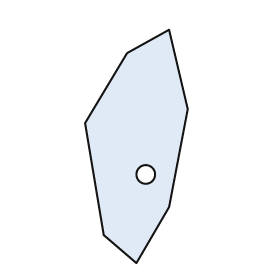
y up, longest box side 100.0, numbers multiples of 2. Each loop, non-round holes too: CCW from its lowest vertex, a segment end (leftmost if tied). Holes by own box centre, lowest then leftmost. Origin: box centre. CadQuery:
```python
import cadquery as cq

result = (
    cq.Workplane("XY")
    .moveTo(0.0, -50.0)
    .lineTo(14.0, -26.0)
    .lineTo(22.0, 16.0)
    .lineTo(14.0, 50.0)
    .lineTo(-4.0, 40.0)
    .lineTo(-22.0, 10.0)
    .lineTo(-14.0, -38.0)
    .close()
    .moveTo(4.0, -12.0)
    .circle(4.0)
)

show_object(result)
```